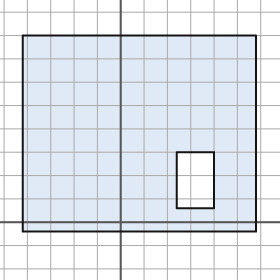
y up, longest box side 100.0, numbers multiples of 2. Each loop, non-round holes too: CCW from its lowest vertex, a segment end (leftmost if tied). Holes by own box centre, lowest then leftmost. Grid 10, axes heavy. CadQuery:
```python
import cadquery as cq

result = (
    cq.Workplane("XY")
    .moveTo(-42.0, -4.0)
    .lineTo(58.0, -4.0)
    .lineTo(58.0, 80.0)
    .lineTo(-42.0, 80.0)
    .close()
    .moveTo(24.0, 6.0)
    .lineTo(40.0, 6.0)
    .lineTo(40.0, 30.0)
    .lineTo(24.0, 30.0)
    .close()
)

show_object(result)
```